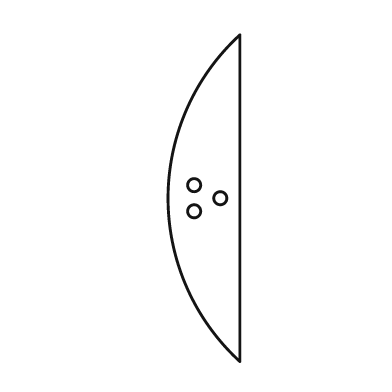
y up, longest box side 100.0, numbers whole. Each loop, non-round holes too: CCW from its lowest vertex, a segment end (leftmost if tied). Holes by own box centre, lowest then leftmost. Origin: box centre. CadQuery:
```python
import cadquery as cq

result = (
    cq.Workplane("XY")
    .moveTo(11.0, -50.0)
    .lineTo(11.0, 50.0)
    .threePointArc((-11.0, 0.0), (11.0, -50.0))
    .close()
    .moveTo(-3.0, -4.0)
    .circle(2.0)
    .moveTo(5.0, 0.0)
    .circle(2.0)
    .moveTo(-3.0, 4.0)
    .circle(2.0)
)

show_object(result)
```